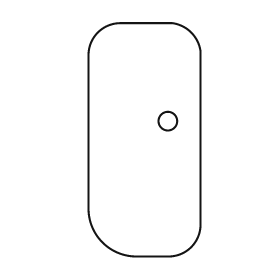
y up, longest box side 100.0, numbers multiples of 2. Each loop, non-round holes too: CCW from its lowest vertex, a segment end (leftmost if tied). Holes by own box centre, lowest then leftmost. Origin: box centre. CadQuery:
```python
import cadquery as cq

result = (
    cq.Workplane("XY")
    .moveTo(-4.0, -50.0)
    .lineTo(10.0, -50.0)
    .threePointArc((20.0, -46.0), (24.0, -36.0))
    .lineTo(24.0, 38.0)
    .threePointArc((20.0, 46.0), (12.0, 50.0))
    .lineTo(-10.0, 50.0)
    .threePointArc((-20.0, 46.0), (-24.0, 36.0))
    .lineTo(-24.0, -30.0)
    .threePointArc((-18.0, -44.0), (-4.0, -50.0))
    .close()
    .moveTo(10.0, 8.0)
    .circle(4.0)
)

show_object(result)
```